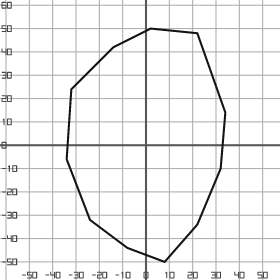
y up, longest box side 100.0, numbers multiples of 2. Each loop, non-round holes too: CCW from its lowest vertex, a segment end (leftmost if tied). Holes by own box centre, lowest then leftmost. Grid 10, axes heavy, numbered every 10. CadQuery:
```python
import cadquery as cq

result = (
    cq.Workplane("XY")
    .moveTo(8.0, -50.0)
    .lineTo(22.0, -34.0)
    .lineTo(32.0, -10.0)
    .lineTo(34.0, 14.0)
    .lineTo(22.0, 48.0)
    .lineTo(2.0, 50.0)
    .lineTo(-14.0, 42.0)
    .lineTo(-32.0, 24.0)
    .lineTo(-34.0, -6.0)
    .lineTo(-24.0, -32.0)
    .lineTo(-8.0, -44.0)
    .close()
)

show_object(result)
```